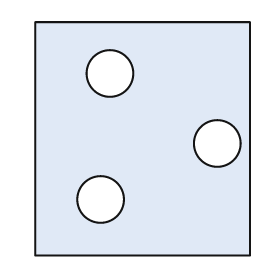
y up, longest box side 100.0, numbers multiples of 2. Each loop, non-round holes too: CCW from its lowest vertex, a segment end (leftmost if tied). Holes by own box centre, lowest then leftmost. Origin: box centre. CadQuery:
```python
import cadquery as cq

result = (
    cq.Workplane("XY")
    .moveTo(-46.0, -50.0)
    .lineTo(46.0, -50.0)
    .lineTo(46.0, 50.0)
    .lineTo(-46.0, 50.0)
    .close()
    .moveTo(-18.0, -26.0)
    .circle(10.0)
    .moveTo(32.0, -2.0)
    .circle(10.0)
    .moveTo(-14.0, 28.0)
    .circle(10.0)
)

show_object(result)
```